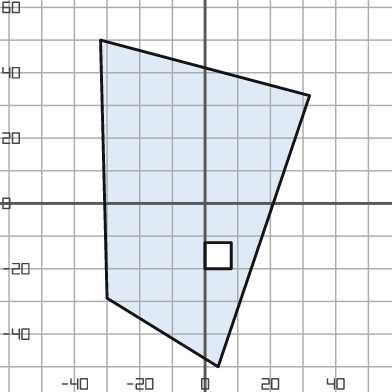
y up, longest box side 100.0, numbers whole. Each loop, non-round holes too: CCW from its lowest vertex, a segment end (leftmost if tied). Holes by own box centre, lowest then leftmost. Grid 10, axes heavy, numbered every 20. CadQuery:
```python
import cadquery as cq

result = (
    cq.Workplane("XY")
    .moveTo(4.0, -50.0)
    .lineTo(32.0, 33.0)
    .lineTo(-32.0, 50.0)
    .lineTo(-30.0, -29.0)
    .close()
    .moveTo(0.0, -20.0)
    .lineTo(8.0, -20.0)
    .lineTo(8.0, -12.0)
    .lineTo(0.0, -12.0)
    .close()
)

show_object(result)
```